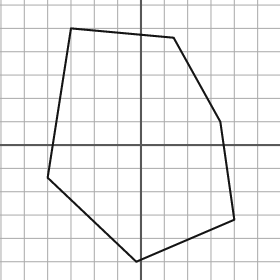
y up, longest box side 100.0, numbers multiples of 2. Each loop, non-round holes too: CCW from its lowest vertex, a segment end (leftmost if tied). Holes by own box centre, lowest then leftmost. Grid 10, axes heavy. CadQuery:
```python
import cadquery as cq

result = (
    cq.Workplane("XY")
    .moveTo(-2.0, -50.0)
    .lineTo(40.0, -32.0)
    .lineTo(34.0, 10.0)
    .lineTo(14.0, 46.0)
    .lineTo(-30.0, 50.0)
    .lineTo(-40.0, -14.0)
    .close()
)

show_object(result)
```